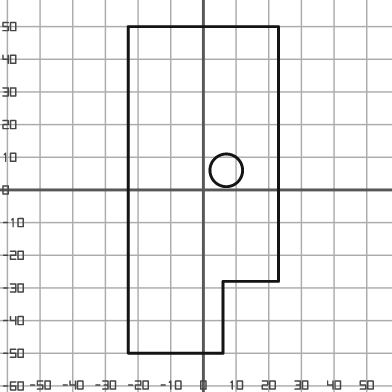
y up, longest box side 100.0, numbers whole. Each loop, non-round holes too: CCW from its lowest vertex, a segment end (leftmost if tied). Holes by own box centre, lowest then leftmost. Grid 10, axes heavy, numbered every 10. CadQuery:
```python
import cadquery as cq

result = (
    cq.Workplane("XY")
    .moveTo(-23.0, -50.0)
    .lineTo(6.0, -50.0)
    .lineTo(6.0, -28.0)
    .lineTo(23.0, -28.0)
    .lineTo(23.0, 50.0)
    .lineTo(-23.0, 50.0)
    .close()
    .moveTo(7.0, 6.0)
    .circle(5.0)
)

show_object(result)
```